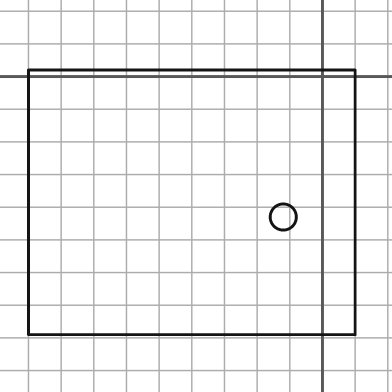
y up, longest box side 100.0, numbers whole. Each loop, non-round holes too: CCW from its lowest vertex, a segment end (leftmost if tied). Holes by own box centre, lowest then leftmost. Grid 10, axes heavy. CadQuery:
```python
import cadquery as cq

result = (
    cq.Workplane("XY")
    .moveTo(-90.0, -79.0)
    .lineTo(10.0, -79.0)
    .lineTo(10.0, 2.0)
    .lineTo(-90.0, 2.0)
    .close()
    .moveTo(-12.0, -43.0)
    .circle(4.0)
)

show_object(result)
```